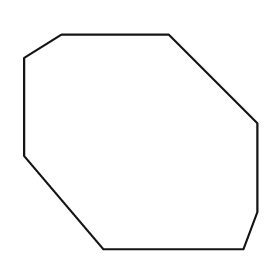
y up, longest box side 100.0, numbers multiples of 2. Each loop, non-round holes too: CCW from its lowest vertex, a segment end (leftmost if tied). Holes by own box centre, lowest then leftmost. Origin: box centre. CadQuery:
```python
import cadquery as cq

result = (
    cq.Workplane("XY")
    .moveTo(-16.0, -46.0)
    .lineTo(44.0, -46.0)
    .lineTo(50.0, -30.0)
    .lineTo(50.0, 8.0)
    .lineTo(12.0, 46.0)
    .lineTo(-34.0, 46.0)
    .lineTo(-50.0, 36.0)
    .lineTo(-50.0, -6.0)
    .close()
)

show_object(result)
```